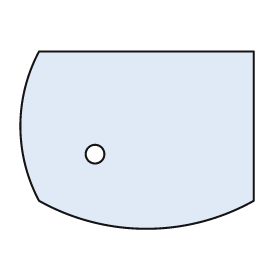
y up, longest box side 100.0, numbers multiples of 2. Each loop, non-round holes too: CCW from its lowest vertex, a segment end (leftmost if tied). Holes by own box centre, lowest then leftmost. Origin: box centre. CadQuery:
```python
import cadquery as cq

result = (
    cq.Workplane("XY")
    .moveTo(-42.0, -26.0)
    .threePointArc((4.0, -38.0), (50.0, -26.0))
    .lineTo(50.0, 38.0)
    .lineTo(-42.0, 38.0)
    .threePointArc((-50.0, 6.0), (-42.0, -26.0))
    .close()
    .moveTo(-18.0, -6.0)
    .circle(4.0)
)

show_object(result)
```